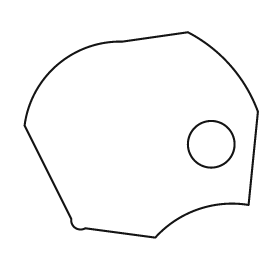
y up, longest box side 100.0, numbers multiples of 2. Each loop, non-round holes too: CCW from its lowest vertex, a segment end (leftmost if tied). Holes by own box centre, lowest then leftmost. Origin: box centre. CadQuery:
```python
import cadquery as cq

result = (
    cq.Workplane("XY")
    .moveTo(6.0, -44.0)
    .threePointArc((24.0, -32.0), (46.0, -30.0))
    .lineTo(50.0, 10.0)
    .threePointArc((38.0, 30.0), (20.0, 44.0))
    .lineTo(-8.0, 40.0)
    .threePointArc((-36.0, 30.0), (-50.0, 4.0))
    .lineTo(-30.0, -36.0)
    .threePointArc((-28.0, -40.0), (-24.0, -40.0))
    .close()
    .moveTo(30.0, -4.0)
    .circle(10.0)
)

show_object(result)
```